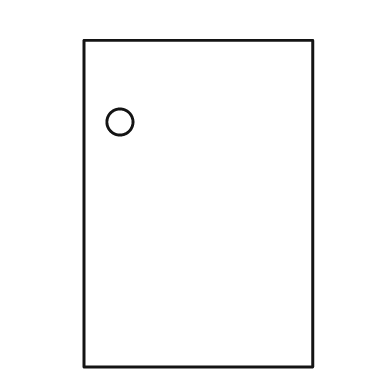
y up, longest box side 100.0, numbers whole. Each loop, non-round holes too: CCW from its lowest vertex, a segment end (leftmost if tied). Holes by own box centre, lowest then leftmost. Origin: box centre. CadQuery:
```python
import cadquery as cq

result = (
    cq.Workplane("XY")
    .moveTo(-35.0, -50.0)
    .lineTo(35.0, -50.0)
    .lineTo(35.0, 50.0)
    .lineTo(-35.0, 50.0)
    .close()
    .moveTo(-24.0, 25.0)
    .circle(4.0)
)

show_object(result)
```